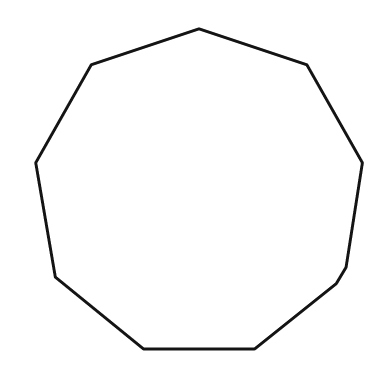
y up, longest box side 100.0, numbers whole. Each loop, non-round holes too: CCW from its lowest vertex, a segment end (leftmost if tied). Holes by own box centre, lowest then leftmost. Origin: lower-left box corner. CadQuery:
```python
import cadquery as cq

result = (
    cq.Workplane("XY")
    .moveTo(33.0, 0.0)
    .lineTo(67.0, 0.0)
    .lineTo(92.0, 20.0)
    .lineTo(95.0, 25.0)
    .lineTo(100.0, 57.0)
    .lineTo(83.0, 87.0)
    .lineTo(50.0, 98.0)
    .lineTo(17.0, 87.0)
    .lineTo(0.0, 57.0)
    .lineTo(6.0, 22.0)
    .close()
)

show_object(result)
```